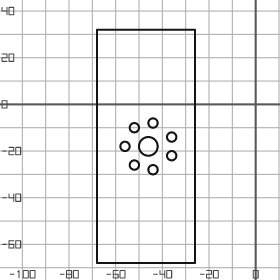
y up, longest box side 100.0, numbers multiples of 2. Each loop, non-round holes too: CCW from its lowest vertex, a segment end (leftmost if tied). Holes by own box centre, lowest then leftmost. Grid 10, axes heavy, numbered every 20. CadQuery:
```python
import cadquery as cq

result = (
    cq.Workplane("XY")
    .moveTo(-68.0, -68.0)
    .lineTo(-26.0, -68.0)
    .lineTo(-26.0, 32.0)
    .lineTo(-68.0, 32.0)
    .close()
    .moveTo(-44.0, -28.0)
    .circle(2.0)
    .moveTo(-52.0, -26.0)
    .circle(2.0)
    .moveTo(-36.0, -22.0)
    .circle(2.0)
    .moveTo(-56.0, -18.0)
    .circle(2.0)
    .moveTo(-46.0, -18.0)
    .circle(4.0)
    .moveTo(-36.0, -14.0)
    .circle(2.0)
    .moveTo(-52.0, -10.0)
    .circle(2.0)
    .moveTo(-44.0, -8.0)
    .circle(2.0)
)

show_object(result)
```